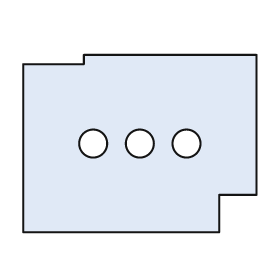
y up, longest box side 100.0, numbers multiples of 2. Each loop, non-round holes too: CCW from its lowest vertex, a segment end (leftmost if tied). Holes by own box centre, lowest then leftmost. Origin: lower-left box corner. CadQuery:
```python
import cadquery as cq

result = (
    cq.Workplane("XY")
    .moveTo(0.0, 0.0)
    .lineTo(84.0, 0.0)
    .lineTo(84.0, 16.0)
    .lineTo(100.0, 16.0)
    .lineTo(100.0, 76.0)
    .lineTo(26.0, 76.0)
    .lineTo(26.0, 72.0)
    .lineTo(0.0, 72.0)
    .close()
    .moveTo(30.0, 38.0)
    .circle(6.0)
    .moveTo(50.0, 38.0)
    .circle(6.0)
    .moveTo(70.0, 38.0)
    .circle(6.0)
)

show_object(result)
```